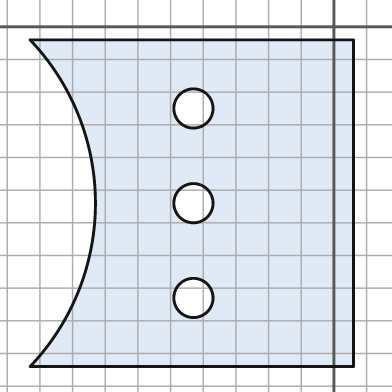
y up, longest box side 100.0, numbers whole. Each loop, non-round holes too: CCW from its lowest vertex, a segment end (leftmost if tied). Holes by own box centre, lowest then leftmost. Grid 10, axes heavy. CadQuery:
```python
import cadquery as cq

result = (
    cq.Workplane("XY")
    .moveTo(-93.0, -104.0)
    .lineTo(6.0, -104.0)
    .lineTo(6.0, -4.0)
    .lineTo(-93.0, -4.0)
    .threePointArc((-73.0, -54.0), (-93.0, -104.0))
    .close()
    .moveTo(-43.0, -83.0)
    .circle(6.0)
    .moveTo(-43.0, -54.0)
    .circle(6.0)
    .moveTo(-43.0, -25.0)
    .circle(6.0)
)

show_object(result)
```